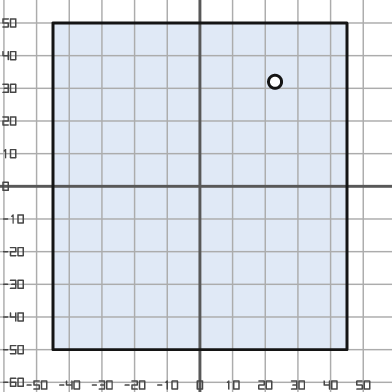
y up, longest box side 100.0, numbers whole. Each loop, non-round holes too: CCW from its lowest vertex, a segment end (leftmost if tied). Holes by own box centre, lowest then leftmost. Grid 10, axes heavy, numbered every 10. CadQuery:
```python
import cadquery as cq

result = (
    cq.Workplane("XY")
    .moveTo(-45.0, -50.0)
    .lineTo(45.0, -50.0)
    .lineTo(45.0, 50.0)
    .lineTo(-45.0, 50.0)
    .close()
    .moveTo(23.0, 32.0)
    .circle(2.0)
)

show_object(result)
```